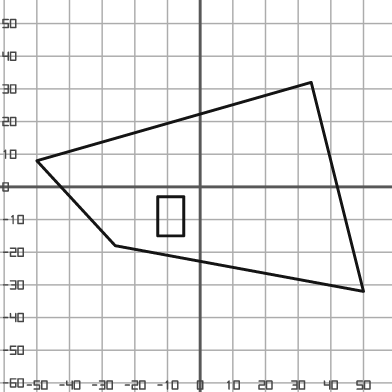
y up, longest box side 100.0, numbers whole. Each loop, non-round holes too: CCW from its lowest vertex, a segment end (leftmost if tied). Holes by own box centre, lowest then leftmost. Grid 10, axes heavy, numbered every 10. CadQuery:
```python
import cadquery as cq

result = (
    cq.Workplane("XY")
    .moveTo(50.0, -32.0)
    .lineTo(34.0, 32.0)
    .lineTo(-50.0, 8.0)
    .lineTo(-26.0, -18.0)
    .close()
    .moveTo(-13.0, -15.0)
    .lineTo(-5.0, -15.0)
    .lineTo(-5.0, -3.0)
    .lineTo(-13.0, -3.0)
    .close()
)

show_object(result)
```